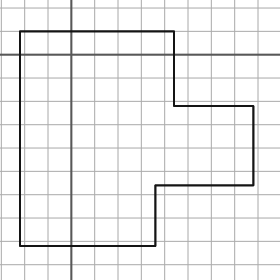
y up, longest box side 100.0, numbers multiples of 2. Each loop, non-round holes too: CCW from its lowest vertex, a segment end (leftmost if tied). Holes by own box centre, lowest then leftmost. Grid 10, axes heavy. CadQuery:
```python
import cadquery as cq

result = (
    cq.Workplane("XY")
    .moveTo(-22.0, -82.0)
    .lineTo(36.0, -82.0)
    .lineTo(36.0, -56.0)
    .lineTo(78.0, -56.0)
    .lineTo(78.0, -22.0)
    .lineTo(44.0, -22.0)
    .lineTo(44.0, 10.0)
    .lineTo(-22.0, 10.0)
    .close()
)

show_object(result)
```